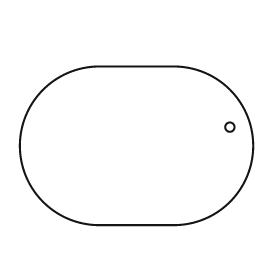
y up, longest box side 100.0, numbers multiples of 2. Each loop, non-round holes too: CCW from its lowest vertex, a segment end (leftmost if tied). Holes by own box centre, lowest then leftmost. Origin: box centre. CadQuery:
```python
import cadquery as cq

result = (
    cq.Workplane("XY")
    .moveTo(-16.0, -34.0)
    .lineTo(16.0, -34.0)
    .threePointArc((50.0, 0.0), (16.0, 34.0))
    .lineTo(-16.0, 34.0)
    .threePointArc((-50.0, 0.0), (-16.0, -34.0))
    .close()
    .moveTo(40.0, 8.0)
    .circle(2.0)
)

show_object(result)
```